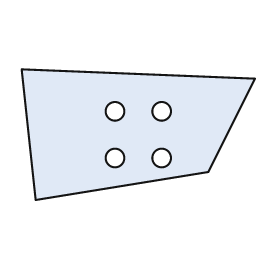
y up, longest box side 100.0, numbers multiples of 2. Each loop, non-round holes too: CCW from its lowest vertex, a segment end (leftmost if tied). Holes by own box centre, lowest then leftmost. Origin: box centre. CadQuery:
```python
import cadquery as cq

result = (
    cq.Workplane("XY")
    .moveTo(-44.0, -28.0)
    .lineTo(30.0, -16.0)
    .lineTo(50.0, 24.0)
    .lineTo(-50.0, 28.0)
    .close()
    .moveTo(-10.0, -10.0)
    .circle(4.0)
    .moveTo(10.0, -10.0)
    .circle(4.0)
    .moveTo(-10.0, 10.0)
    .circle(4.0)
    .moveTo(10.0, 10.0)
    .circle(4.0)
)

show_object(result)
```